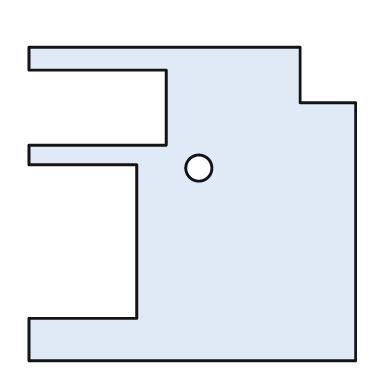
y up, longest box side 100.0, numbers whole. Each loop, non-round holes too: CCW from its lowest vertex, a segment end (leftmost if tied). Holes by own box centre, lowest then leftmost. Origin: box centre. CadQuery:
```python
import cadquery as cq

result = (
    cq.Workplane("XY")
    .moveTo(-50.0, -48.0)
    .lineTo(50.0, -48.0)
    .lineTo(50.0, 31.0)
    .lineTo(33.0, 31.0)
    .lineTo(33.0, 48.0)
    .lineTo(-50.0, 48.0)
    .lineTo(-50.0, 41.0)
    .lineTo(-8.0, 41.0)
    .lineTo(-8.0, 18.0)
    .lineTo(-50.0, 18.0)
    .lineTo(-50.0, 12.0)
    .lineTo(-17.0, 12.0)
    .lineTo(-17.0, -35.0)
    .lineTo(-50.0, -35.0)
    .close()
    .moveTo(2.0, 11.0)
    .circle(4.0)
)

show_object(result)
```